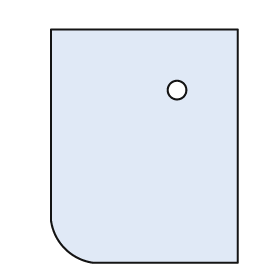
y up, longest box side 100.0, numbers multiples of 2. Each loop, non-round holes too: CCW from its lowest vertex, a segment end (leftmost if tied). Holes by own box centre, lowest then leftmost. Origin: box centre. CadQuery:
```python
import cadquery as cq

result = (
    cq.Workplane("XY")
    .moveTo(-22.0, -50.0)
    .lineTo(40.0, -50.0)
    .lineTo(40.0, 50.0)
    .lineTo(-40.0, 50.0)
    .lineTo(-40.0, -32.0)
    .threePointArc((-34.0, -44.0), (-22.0, -50.0))
    .close()
    .moveTo(14.0, 24.0)
    .circle(4.0)
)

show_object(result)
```